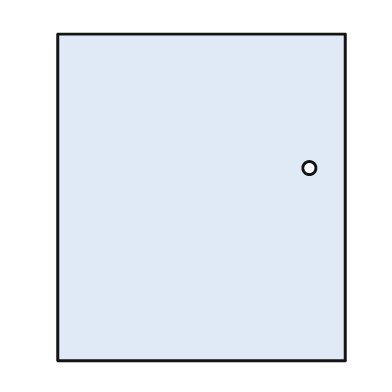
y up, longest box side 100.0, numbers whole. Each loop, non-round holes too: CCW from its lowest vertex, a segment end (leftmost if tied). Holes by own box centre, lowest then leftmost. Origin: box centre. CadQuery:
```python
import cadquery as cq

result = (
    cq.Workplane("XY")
    .moveTo(-44.0, -50.0)
    .lineTo(44.0, -50.0)
    .lineTo(44.0, 50.0)
    .lineTo(-44.0, 50.0)
    .close()
    .moveTo(33.0, 9.0)
    .circle(2.0)
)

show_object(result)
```